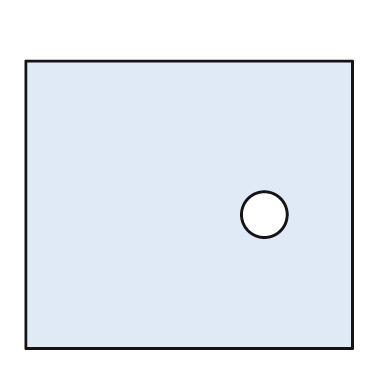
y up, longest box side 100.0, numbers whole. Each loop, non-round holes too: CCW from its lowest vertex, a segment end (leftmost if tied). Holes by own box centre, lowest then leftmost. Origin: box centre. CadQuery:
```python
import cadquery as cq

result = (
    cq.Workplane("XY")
    .moveTo(-50.0, -44.0)
    .lineTo(50.0, -44.0)
    .lineTo(50.0, 44.0)
    .lineTo(-50.0, 44.0)
    .close()
    .moveTo(23.0, -3.0)
    .circle(7.0)
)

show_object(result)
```